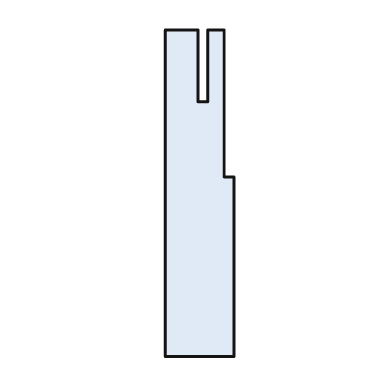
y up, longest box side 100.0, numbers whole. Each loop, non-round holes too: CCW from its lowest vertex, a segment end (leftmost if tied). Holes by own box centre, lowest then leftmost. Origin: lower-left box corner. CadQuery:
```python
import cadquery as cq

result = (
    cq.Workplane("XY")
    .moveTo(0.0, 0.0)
    .lineTo(21.0, 0.0)
    .lineTo(21.0, 55.0)
    .lineTo(18.0, 55.0)
    .lineTo(18.0, 100.0)
    .lineTo(13.0, 100.0)
    .lineTo(13.0, 78.0)
    .lineTo(10.0, 78.0)
    .lineTo(10.0, 100.0)
    .lineTo(0.0, 100.0)
    .close()
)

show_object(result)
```